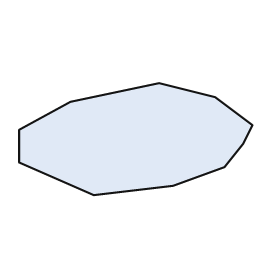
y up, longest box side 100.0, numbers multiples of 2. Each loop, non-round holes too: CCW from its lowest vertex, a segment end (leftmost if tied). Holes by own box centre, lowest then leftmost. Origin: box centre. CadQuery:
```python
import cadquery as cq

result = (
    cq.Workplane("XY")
    .moveTo(-18.0, -24.0)
    .lineTo(16.0, -20.0)
    .lineTo(38.0, -12.0)
    .lineTo(46.0, -2.0)
    .lineTo(50.0, 6.0)
    .lineTo(34.0, 18.0)
    .lineTo(10.0, 24.0)
    .lineTo(-28.0, 16.0)
    .lineTo(-50.0, 4.0)
    .lineTo(-50.0, -10.0)
    .close()
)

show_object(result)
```